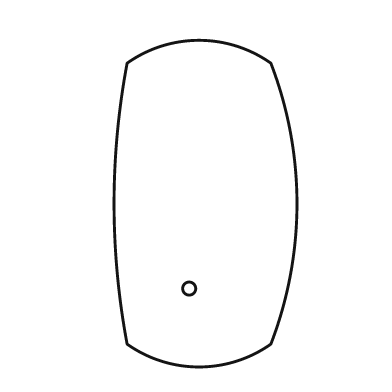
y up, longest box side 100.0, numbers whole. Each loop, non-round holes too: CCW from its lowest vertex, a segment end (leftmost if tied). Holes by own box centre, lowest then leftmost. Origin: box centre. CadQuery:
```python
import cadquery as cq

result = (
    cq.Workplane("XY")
    .moveTo(-24.0, -43.0)
    .threePointArc((-2.0, -50.0), (20.0, -43.0))
    .threePointArc((28.0, 0.0), (20.0, 43.0))
    .threePointArc((-2.0, 50.0), (-24.0, 43.0))
    .threePointArc((-28.0, 0.0), (-24.0, -43.0))
    .close()
    .moveTo(-5.0, -26.0)
    .circle(2.0)
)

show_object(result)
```